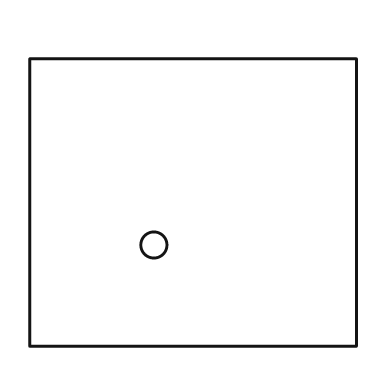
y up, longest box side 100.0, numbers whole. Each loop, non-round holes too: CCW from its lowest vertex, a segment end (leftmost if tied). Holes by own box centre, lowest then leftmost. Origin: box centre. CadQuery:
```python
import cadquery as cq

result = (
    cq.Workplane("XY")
    .moveTo(-50.0, -44.0)
    .lineTo(50.0, -44.0)
    .lineTo(50.0, 44.0)
    .lineTo(-50.0, 44.0)
    .close()
    .moveTo(-12.0, -13.0)
    .circle(4.0)
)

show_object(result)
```